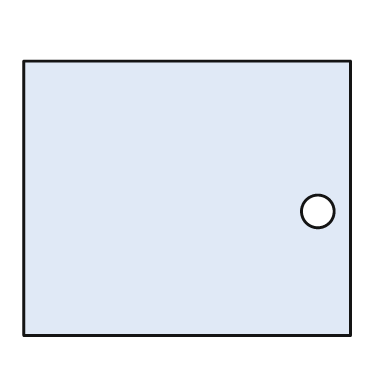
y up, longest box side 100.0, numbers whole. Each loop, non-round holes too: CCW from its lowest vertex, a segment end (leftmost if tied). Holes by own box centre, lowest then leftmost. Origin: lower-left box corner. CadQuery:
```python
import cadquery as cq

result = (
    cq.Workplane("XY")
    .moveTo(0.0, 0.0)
    .lineTo(100.0, 0.0)
    .lineTo(100.0, 84.0)
    .lineTo(0.0, 84.0)
    .close()
    .moveTo(90.0, 38.0)
    .circle(5.0)
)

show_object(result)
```